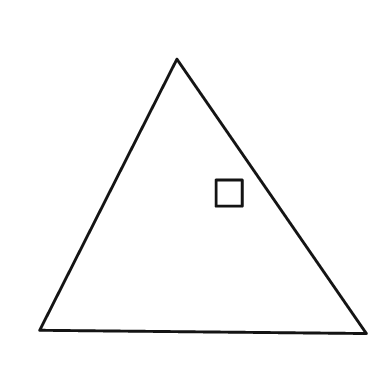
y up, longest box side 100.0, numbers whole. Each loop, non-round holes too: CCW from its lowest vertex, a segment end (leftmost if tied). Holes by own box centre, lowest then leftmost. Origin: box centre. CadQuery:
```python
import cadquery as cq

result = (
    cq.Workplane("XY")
    .moveTo(50.0, -42.0)
    .lineTo(-8.0, 42.0)
    .lineTo(-50.0, -41.0)
    .close()
    .moveTo(4.0, -3.0)
    .lineTo(12.0, -3.0)
    .lineTo(12.0, 5.0)
    .lineTo(4.0, 5.0)
    .close()
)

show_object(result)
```